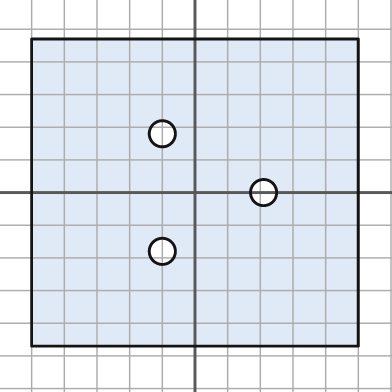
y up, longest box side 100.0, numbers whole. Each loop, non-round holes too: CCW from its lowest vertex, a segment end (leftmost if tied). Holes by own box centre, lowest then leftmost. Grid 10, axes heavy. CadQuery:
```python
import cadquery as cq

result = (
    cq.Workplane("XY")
    .moveTo(-50.0, -47.0)
    .lineTo(50.0, -47.0)
    .lineTo(50.0, 47.0)
    .lineTo(-50.0, 47.0)
    .close()
    .moveTo(-10.0, -18.0)
    .circle(4.0)
    .moveTo(21.0, 0.0)
    .circle(4.0)
    .moveTo(-10.0, 18.0)
    .circle(4.0)
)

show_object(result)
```